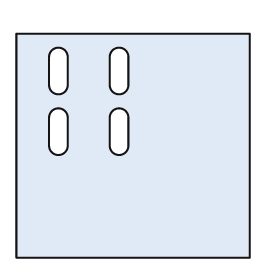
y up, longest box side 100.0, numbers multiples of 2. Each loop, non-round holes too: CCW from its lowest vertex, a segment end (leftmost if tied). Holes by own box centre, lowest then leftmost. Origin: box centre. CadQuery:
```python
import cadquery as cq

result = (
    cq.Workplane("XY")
    .moveTo(-50.0, -48.0)
    .lineTo(50.0, -48.0)
    .lineTo(50.0, 48.0)
    .lineTo(-50.0, 48.0)
    .close()
    .moveTo(-36.0, 0.0)
    .threePointArc((-32.0, -4.0), (-28.0, 0.0))
    .lineTo(-28.0, 12.0)
    .threePointArc((-32.0, 16.0), (-36.0, 12.0))
    .close()
    .moveTo(-10.0, 0.0)
    .threePointArc((-6.0, -4.0), (-2.0, 0.0))
    .lineTo(-2.0, 12.0)
    .threePointArc((-6.0, 16.0), (-10.0, 12.0))
    .close()
    .moveTo(-36.0, 26.0)
    .threePointArc((-32.0, 22.0), (-28.0, 26.0))
    .lineTo(-28.0, 38.0)
    .threePointArc((-32.0, 42.0), (-36.0, 38.0))
    .close()
    .moveTo(-10.0, 26.0)
    .threePointArc((-6.0, 22.0), (-2.0, 26.0))
    .lineTo(-2.0, 38.0)
    .threePointArc((-6.0, 42.0), (-10.0, 38.0))
    .close()
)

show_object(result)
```